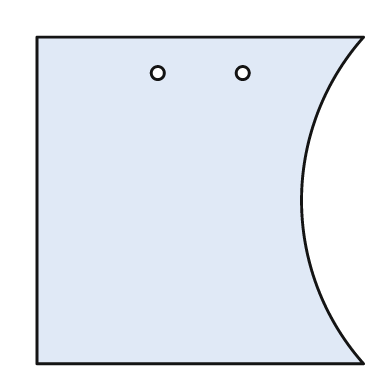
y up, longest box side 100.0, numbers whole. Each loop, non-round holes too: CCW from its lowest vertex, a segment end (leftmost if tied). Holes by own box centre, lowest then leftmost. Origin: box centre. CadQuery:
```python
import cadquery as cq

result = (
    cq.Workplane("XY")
    .moveTo(-50.0, -50.0)
    .lineTo(50.0, -50.0)
    .threePointArc((31.0, 0.0), (50.0, 50.0))
    .lineTo(-50.0, 50.0)
    .close()
    .moveTo(-13.0, 39.0)
    .circle(2.0)
    .moveTo(13.0, 39.0)
    .circle(2.0)
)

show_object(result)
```